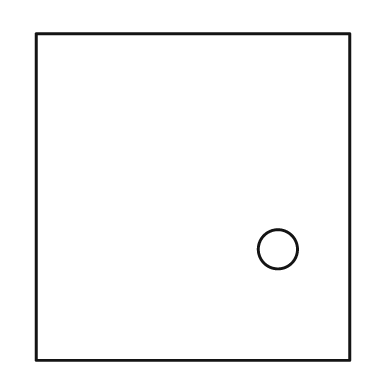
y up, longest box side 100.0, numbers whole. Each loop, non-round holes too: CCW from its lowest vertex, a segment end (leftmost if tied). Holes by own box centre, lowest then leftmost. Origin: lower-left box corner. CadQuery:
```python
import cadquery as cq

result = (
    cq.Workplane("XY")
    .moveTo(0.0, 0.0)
    .lineTo(96.0, 0.0)
    .lineTo(96.0, 100.0)
    .lineTo(0.0, 100.0)
    .close()
    .moveTo(74.0, 34.0)
    .circle(6.0)
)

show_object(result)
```